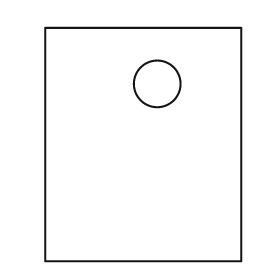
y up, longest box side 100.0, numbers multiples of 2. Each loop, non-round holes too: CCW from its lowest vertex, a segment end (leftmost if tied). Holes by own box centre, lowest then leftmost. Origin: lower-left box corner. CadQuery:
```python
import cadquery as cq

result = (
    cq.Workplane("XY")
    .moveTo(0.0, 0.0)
    .lineTo(84.0, 0.0)
    .lineTo(84.0, 100.0)
    .lineTo(0.0, 100.0)
    .close()
    .moveTo(48.0, 76.0)
    .circle(10.0)
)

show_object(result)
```